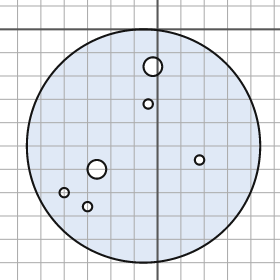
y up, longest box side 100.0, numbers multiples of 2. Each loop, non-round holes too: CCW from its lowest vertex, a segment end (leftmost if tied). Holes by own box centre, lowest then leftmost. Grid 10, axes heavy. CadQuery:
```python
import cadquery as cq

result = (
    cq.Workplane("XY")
    .moveTo(-6.0, -50.0)
    .circle(50.0)
    .moveTo(-30.0, -76.0)
    .circle(2.0)
    .moveTo(-40.0, -70.0)
    .circle(2.0)
    .moveTo(-26.0, -60.0)
    .circle(4.0)
    .moveTo(18.0, -56.0)
    .circle(2.0)
    .moveTo(-4.0, -32.0)
    .circle(2.0)
    .moveTo(-2.0, -16.0)
    .circle(4.0)
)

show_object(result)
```